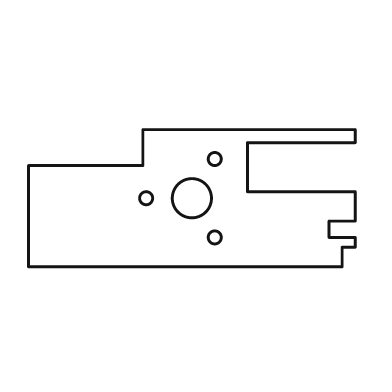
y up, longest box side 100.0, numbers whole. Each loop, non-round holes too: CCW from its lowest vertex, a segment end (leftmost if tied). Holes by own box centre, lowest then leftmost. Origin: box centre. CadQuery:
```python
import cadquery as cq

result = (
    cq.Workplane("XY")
    .moveTo(-50.0, -21.0)
    .lineTo(46.0, -21.0)
    .lineTo(46.0, -15.0)
    .lineTo(50.0, -15.0)
    .lineTo(50.0, -12.0)
    .lineTo(42.0, -12.0)
    .lineTo(42.0, -7.0)
    .lineTo(50.0, -7.0)
    .lineTo(50.0, 2.0)
    .lineTo(17.0, 2.0)
    .lineTo(17.0, 17.0)
    .lineTo(50.0, 17.0)
    .lineTo(50.0, 21.0)
    .lineTo(-15.0, 21.0)
    .lineTo(-15.0, 10.0)
    .lineTo(-50.0, 10.0)
    .close()
    .moveTo(7.0, -12.0)
    .circle(2.0)
    .moveTo(-14.0, 0.0)
    .circle(2.0)
    .moveTo(0.0, 0.0)
    .circle(6.0)
    .moveTo(7.0, 12.0)
    .circle(2.0)
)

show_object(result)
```